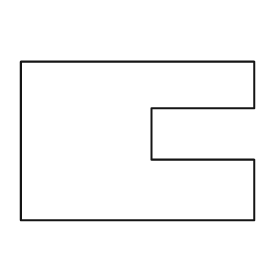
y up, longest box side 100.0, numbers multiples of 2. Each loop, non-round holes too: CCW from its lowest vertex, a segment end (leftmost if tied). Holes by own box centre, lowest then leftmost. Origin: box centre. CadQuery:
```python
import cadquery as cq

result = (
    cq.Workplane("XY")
    .moveTo(-50.0, -34.0)
    .lineTo(50.0, -34.0)
    .lineTo(50.0, -8.0)
    .lineTo(6.0, -8.0)
    .lineTo(6.0, 14.0)
    .lineTo(50.0, 14.0)
    .lineTo(50.0, 34.0)
    .lineTo(-50.0, 34.0)
    .close()
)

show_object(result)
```